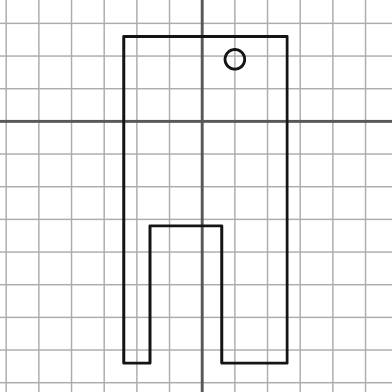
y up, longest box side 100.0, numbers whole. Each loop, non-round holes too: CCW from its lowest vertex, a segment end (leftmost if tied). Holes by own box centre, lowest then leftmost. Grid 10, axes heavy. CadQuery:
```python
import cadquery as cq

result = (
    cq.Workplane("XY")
    .moveTo(-24.0, -74.0)
    .lineTo(-16.0, -74.0)
    .lineTo(-16.0, -32.0)
    .lineTo(6.0, -32.0)
    .lineTo(6.0, -74.0)
    .lineTo(26.0, -74.0)
    .lineTo(26.0, 26.0)
    .lineTo(-24.0, 26.0)
    .close()
    .moveTo(10.0, 19.0)
    .circle(3.0)
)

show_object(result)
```